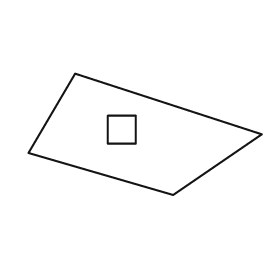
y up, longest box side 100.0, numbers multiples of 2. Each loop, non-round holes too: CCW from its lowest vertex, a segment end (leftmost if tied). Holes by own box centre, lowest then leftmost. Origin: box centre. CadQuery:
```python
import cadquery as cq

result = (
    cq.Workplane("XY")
    .moveTo(12.0, -26.0)
    .lineTo(50.0, 0.0)
    .lineTo(-30.0, 26.0)
    .lineTo(-50.0, -8.0)
    .close()
    .moveTo(-16.0, -4.0)
    .lineTo(-4.0, -4.0)
    .lineTo(-4.0, 8.0)
    .lineTo(-16.0, 8.0)
    .close()
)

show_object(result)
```